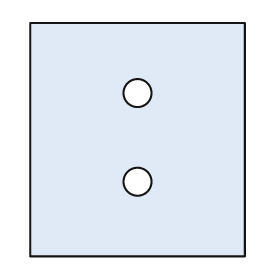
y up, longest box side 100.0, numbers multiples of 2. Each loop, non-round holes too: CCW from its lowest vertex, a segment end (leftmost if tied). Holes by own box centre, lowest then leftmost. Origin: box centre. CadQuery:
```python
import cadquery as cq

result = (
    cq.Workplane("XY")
    .moveTo(-46.0, -50.0)
    .lineTo(46.0, -50.0)
    .lineTo(46.0, 50.0)
    .lineTo(-46.0, 50.0)
    .close()
    .moveTo(0.0, -18.0)
    .circle(6.0)
    .moveTo(0.0, 20.0)
    .circle(6.0)
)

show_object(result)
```